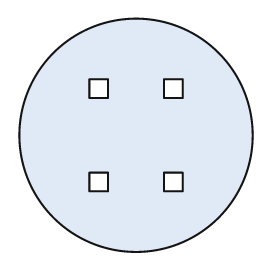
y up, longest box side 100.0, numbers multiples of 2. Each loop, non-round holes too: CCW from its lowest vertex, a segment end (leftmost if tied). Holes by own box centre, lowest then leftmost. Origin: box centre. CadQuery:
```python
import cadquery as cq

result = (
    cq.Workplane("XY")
    .moveTo(0.0, 0.0)
    .circle(50.0)
    .moveTo(-20.0, -24.0)
    .lineTo(-12.0, -24.0)
    .lineTo(-12.0, -16.0)
    .lineTo(-20.0, -16.0)
    .close()
    .moveTo(12.0, -24.0)
    .lineTo(20.0, -24.0)
    .lineTo(20.0, -16.0)
    .lineTo(12.0, -16.0)
    .close()
    .moveTo(-20.0, 16.0)
    .lineTo(-12.0, 16.0)
    .lineTo(-12.0, 24.0)
    .lineTo(-20.0, 24.0)
    .close()
    .moveTo(12.0, 16.0)
    .lineTo(20.0, 16.0)
    .lineTo(20.0, 24.0)
    .lineTo(12.0, 24.0)
    .close()
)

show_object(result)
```